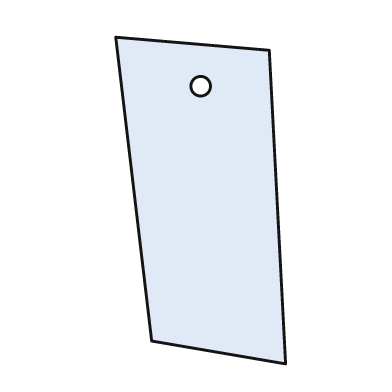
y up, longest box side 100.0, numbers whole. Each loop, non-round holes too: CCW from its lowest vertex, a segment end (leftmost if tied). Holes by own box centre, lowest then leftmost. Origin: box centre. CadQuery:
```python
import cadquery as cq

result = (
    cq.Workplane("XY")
    .moveTo(26.0, -50.0)
    .lineTo(21.0, 46.0)
    .lineTo(-26.0, 50.0)
    .lineTo(-15.0, -43.0)
    .close()
    .moveTo(0.0, 35.0)
    .circle(3.0)
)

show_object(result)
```